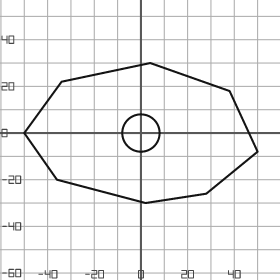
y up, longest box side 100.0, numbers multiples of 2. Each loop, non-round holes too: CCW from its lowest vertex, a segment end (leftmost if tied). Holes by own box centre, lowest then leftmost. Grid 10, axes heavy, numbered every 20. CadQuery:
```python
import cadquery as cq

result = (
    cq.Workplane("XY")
    .moveTo(2.0, -30.0)
    .lineTo(28.0, -26.0)
    .lineTo(50.0, -8.0)
    .lineTo(38.0, 18.0)
    .lineTo(4.0, 30.0)
    .lineTo(-34.0, 22.0)
    .lineTo(-50.0, 0.0)
    .lineTo(-36.0, -20.0)
    .close()
    .moveTo(0.0, 0.0)
    .circle(8.0)
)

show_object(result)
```